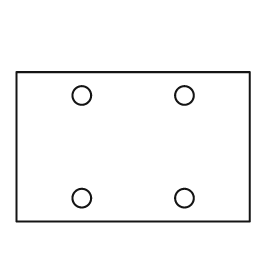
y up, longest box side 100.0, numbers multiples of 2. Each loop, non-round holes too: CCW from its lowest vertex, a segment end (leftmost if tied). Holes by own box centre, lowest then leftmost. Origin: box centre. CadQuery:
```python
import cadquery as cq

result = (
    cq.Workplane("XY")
    .moveTo(-50.0, -32.0)
    .lineTo(50.0, -32.0)
    .lineTo(50.0, 32.0)
    .lineTo(-50.0, 32.0)
    .close()
    .moveTo(-22.0, -22.0)
    .circle(4.0)
    .moveTo(22.0, -22.0)
    .circle(4.0)
    .moveTo(-22.0, 22.0)
    .circle(4.0)
    .moveTo(22.0, 22.0)
    .circle(4.0)
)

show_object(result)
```